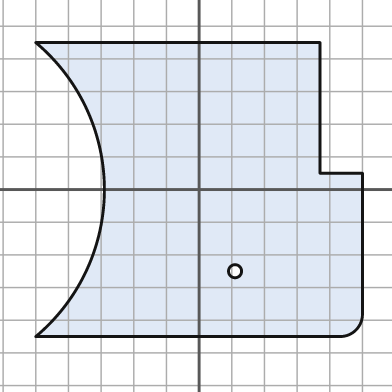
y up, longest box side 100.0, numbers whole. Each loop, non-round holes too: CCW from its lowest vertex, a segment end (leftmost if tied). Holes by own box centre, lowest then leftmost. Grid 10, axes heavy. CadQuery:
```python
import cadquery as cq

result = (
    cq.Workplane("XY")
    .moveTo(-50.0, -45.0)
    .lineTo(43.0, -45.0)
    .threePointArc((48.0, -43.0), (50.0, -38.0))
    .lineTo(50.0, 5.0)
    .lineTo(37.0, 5.0)
    .lineTo(37.0, 45.0)
    .lineTo(-50.0, 45.0)
    .threePointArc((-29.0, 0.0), (-50.0, -45.0))
    .close()
    .moveTo(11.0, -25.0)
    .circle(2.0)
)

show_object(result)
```